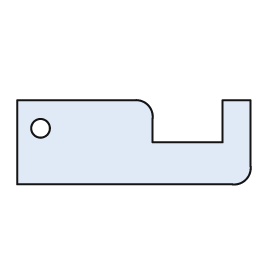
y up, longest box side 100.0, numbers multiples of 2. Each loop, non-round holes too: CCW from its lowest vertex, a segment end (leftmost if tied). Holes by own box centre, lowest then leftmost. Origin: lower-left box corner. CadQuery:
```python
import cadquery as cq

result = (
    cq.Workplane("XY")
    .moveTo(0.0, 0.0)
    .lineTo(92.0, 0.0)
    .threePointArc((98.0, 2.0), (100.0, 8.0))
    .lineTo(100.0, 36.0)
    .lineTo(88.0, 36.0)
    .lineTo(88.0, 18.0)
    .lineTo(58.0, 18.0)
    .lineTo(58.0, 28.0)
    .threePointArc((56.0, 34.0), (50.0, 36.0))
    .lineTo(0.0, 36.0)
    .close()
    .moveTo(10.0, 24.0)
    .circle(4.0)
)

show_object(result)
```